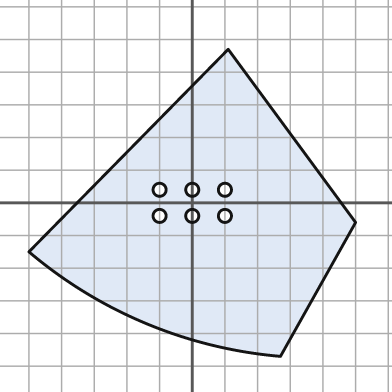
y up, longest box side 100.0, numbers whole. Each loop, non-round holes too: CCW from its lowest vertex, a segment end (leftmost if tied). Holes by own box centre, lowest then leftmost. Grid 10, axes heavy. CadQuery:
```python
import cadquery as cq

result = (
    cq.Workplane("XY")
    .moveTo(27.0, -47.0)
    .lineTo(50.0, -6.0)
    .lineTo(11.0, 47.0)
    .lineTo(-50.0, -15.0)
    .threePointArc((-14.0, -37.0), (27.0, -47.0))
    .close()
    .moveTo(-10.0, -4.0)
    .circle(2.0)
    .moveTo(0.0, -4.0)
    .circle(2.0)
    .moveTo(10.0, -4.0)
    .circle(2.0)
    .moveTo(-10.0, 4.0)
    .circle(2.0)
    .moveTo(0.0, 4.0)
    .circle(2.0)
    .moveTo(10.0, 4.0)
    .circle(2.0)
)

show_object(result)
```